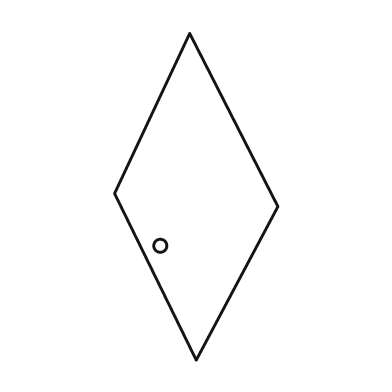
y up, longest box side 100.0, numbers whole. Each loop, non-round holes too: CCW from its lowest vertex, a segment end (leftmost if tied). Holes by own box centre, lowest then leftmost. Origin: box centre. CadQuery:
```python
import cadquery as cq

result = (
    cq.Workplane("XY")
    .moveTo(0.0, -50.0)
    .lineTo(25.0, -3.0)
    .lineTo(-2.0, 50.0)
    .lineTo(-25.0, 1.0)
    .close()
    .moveTo(-11.0, -15.0)
    .circle(2.0)
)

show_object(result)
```